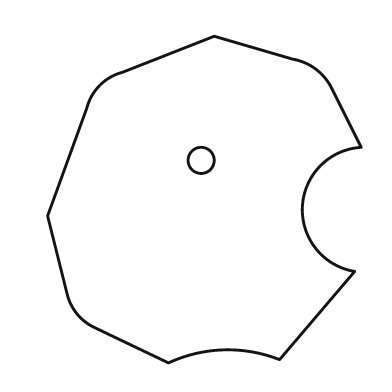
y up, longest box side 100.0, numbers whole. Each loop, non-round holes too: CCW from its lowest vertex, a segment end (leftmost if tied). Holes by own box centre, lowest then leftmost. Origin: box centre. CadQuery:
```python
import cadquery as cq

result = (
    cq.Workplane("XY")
    .moveTo(-11.0, -50.0)
    .threePointArc((6.0, -46.0), (23.0, -49.0))
    .lineTo(46.0, -22.0)
    .threePointArc((30.0, -2.0), (48.0, 16.0))
    .lineTo(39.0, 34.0)
    .threePointArc((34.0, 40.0), (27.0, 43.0))
    .lineTo(3.0, 50.0)
    .lineTo(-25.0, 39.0)
    .threePointArc((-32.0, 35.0), (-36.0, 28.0))
    .lineTo(-48.0, -5.0)
    .lineTo(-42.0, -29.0)
    .threePointArc((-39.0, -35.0), (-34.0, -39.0))
    .close()
    .moveTo(-1.0, 12.0)
    .circle(4.0)
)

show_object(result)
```